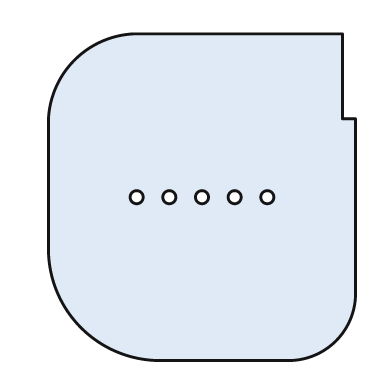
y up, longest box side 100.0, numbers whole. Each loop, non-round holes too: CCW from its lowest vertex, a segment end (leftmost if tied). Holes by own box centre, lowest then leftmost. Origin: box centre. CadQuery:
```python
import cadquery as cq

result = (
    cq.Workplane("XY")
    .moveTo(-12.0, -50.0)
    .lineTo(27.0, -50.0)
    .threePointArc((41.0, -44.0), (47.0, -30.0))
    .lineTo(47.0, 24.0)
    .lineTo(43.0, 24.0)
    .lineTo(43.0, 50.0)
    .lineTo(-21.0, 50.0)
    .threePointArc((-39.0, 42.0), (-47.0, 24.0))
    .lineTo(-47.0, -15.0)
    .threePointArc((-37.0, -40.0), (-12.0, -50.0))
    .close()
    .moveTo(-20.0, 0.0)
    .circle(2.0)
    .moveTo(-10.0, 0.0)
    .circle(2.0)
    .moveTo(0.0, 0.0)
    .circle(2.0)
    .moveTo(10.0, 0.0)
    .circle(2.0)
    .moveTo(20.0, 0.0)
    .circle(2.0)
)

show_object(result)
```